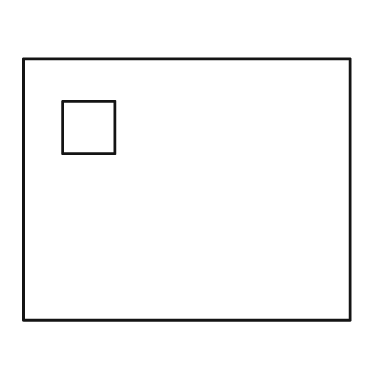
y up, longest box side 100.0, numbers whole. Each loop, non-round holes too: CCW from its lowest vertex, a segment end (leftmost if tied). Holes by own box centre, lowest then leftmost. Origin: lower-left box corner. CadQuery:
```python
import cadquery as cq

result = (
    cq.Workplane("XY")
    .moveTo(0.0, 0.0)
    .lineTo(100.0, 0.0)
    .lineTo(100.0, 80.0)
    .lineTo(0.0, 80.0)
    .close()
    .moveTo(12.0, 51.0)
    .lineTo(28.0, 51.0)
    .lineTo(28.0, 67.0)
    .lineTo(12.0, 67.0)
    .close()
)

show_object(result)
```